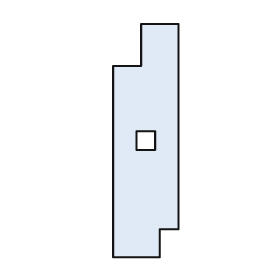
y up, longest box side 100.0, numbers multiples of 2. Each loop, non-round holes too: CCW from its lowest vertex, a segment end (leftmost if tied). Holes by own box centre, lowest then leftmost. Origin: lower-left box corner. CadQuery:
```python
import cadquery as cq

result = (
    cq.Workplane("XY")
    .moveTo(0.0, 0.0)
    .lineTo(20.0, 0.0)
    .lineTo(20.0, 12.0)
    .lineTo(28.0, 12.0)
    .lineTo(28.0, 100.0)
    .lineTo(12.0, 100.0)
    .lineTo(12.0, 82.0)
    .lineTo(0.0, 82.0)
    .close()
    .moveTo(10.0, 46.0)
    .lineTo(18.0, 46.0)
    .lineTo(18.0, 54.0)
    .lineTo(10.0, 54.0)
    .close()
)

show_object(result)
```